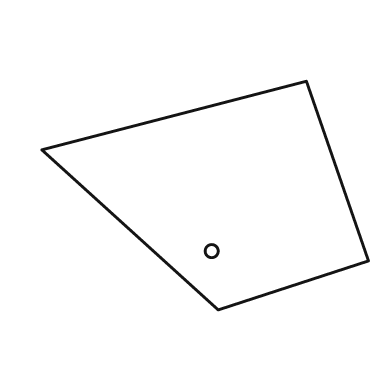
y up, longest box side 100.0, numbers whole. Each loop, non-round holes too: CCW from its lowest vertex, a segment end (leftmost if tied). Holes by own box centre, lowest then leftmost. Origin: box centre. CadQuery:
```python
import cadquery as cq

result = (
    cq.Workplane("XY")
    .moveTo(4.0, -35.0)
    .lineTo(50.0, -20.0)
    .lineTo(31.0, 35.0)
    .lineTo(-50.0, 14.0)
    .close()
    .moveTo(2.0, -17.0)
    .circle(2.0)
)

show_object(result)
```